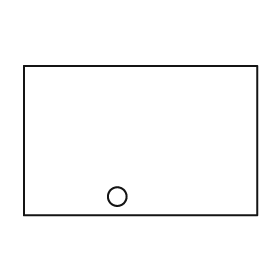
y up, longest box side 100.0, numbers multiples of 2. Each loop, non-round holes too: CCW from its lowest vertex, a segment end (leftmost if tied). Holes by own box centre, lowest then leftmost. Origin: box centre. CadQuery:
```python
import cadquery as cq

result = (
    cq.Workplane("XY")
    .moveTo(-50.0, -32.0)
    .lineTo(50.0, -32.0)
    .lineTo(50.0, 32.0)
    .lineTo(-50.0, 32.0)
    .close()
    .moveTo(-10.0, -24.0)
    .circle(4.0)
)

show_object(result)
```